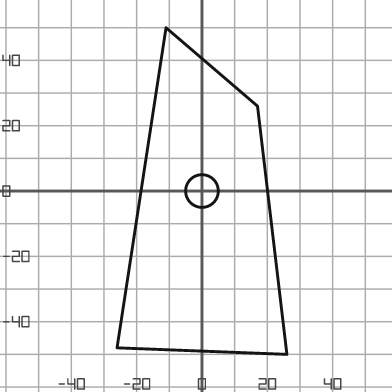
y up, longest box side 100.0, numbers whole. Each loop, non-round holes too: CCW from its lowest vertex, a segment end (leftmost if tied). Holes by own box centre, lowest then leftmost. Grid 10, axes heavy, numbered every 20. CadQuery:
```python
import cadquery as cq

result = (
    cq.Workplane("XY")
    .moveTo(26.0, -50.0)
    .lineTo(17.0, 26.0)
    .lineTo(-11.0, 50.0)
    .lineTo(-26.0, -48.0)
    .close()
    .moveTo(0.0, 0.0)
    .circle(5.0)
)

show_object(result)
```